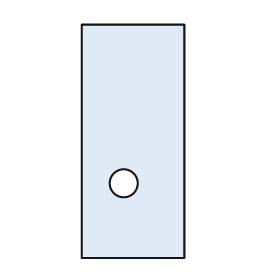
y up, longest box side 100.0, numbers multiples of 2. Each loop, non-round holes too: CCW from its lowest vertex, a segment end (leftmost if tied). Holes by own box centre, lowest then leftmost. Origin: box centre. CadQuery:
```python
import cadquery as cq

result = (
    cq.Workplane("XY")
    .moveTo(-22.0, -50.0)
    .lineTo(22.0, -50.0)
    .lineTo(22.0, 50.0)
    .lineTo(-22.0, 50.0)
    .close()
    .moveTo(-4.0, -18.0)
    .circle(6.0)
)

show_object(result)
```